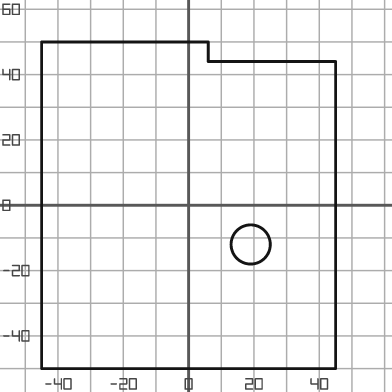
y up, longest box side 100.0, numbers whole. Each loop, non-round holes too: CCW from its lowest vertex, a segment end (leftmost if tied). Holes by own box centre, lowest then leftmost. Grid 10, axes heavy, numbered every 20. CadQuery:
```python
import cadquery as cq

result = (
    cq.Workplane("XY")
    .moveTo(-45.0, -50.0)
    .lineTo(45.0, -50.0)
    .lineTo(45.0, 44.0)
    .lineTo(6.0, 44.0)
    .lineTo(6.0, 50.0)
    .lineTo(-45.0, 50.0)
    .close()
    .moveTo(19.0, -12.0)
    .circle(6.0)
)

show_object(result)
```